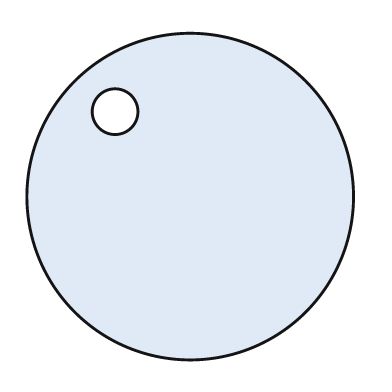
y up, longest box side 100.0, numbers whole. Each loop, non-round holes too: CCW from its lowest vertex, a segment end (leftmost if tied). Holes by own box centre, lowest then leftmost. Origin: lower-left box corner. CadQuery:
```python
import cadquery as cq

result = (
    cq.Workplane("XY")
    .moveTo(50.0, 50.0)
    .circle(50.0)
    .moveTo(27.0, 76.0)
    .circle(7.0)
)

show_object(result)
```